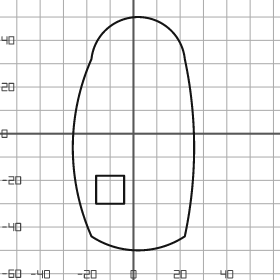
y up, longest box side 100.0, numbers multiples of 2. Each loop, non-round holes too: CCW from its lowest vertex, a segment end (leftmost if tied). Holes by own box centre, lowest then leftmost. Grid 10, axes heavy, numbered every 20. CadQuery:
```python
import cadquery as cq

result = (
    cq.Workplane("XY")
    .moveTo(-18.0, -44.0)
    .threePointArc((2.0, -50.0), (22.0, -44.0))
    .threePointArc((26.0, -6.0), (22.0, 32.0))
    .threePointArc((2.0, 50.0), (-18.0, 32.0))
    .threePointArc((-26.0, -6.0), (-18.0, -44.0))
    .close()
    .moveTo(-16.0, -30.0)
    .lineTo(-4.0, -30.0)
    .lineTo(-4.0, -18.0)
    .lineTo(-16.0, -18.0)
    .close()
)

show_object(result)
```